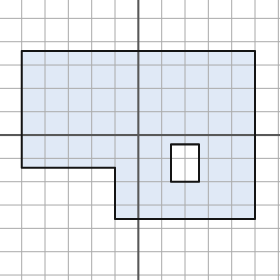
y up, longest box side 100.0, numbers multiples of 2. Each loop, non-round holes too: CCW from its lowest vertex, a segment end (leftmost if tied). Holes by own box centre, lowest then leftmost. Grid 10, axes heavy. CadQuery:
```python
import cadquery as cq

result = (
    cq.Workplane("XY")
    .moveTo(-10.0, -36.0)
    .lineTo(50.0, -36.0)
    .lineTo(50.0, 36.0)
    .lineTo(-50.0, 36.0)
    .lineTo(-50.0, -14.0)
    .lineTo(-10.0, -14.0)
    .close()
    .moveTo(14.0, -20.0)
    .lineTo(26.0, -20.0)
    .lineTo(26.0, -4.0)
    .lineTo(14.0, -4.0)
    .close()
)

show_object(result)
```